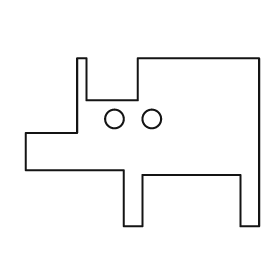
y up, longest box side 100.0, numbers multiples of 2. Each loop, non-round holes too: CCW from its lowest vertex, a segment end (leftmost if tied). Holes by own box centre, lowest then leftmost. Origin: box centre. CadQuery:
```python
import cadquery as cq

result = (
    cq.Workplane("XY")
    .moveTo(-8.0, -36.0)
    .lineTo(0.0, -36.0)
    .lineTo(0.0, -14.0)
    .lineTo(42.0, -14.0)
    .lineTo(42.0, -36.0)
    .lineTo(50.0, -36.0)
    .lineTo(50.0, 36.0)
    .lineTo(-2.0, 36.0)
    .lineTo(-2.0, 18.0)
    .lineTo(-24.0, 18.0)
    .lineTo(-24.0, 36.0)
    .lineTo(-28.0, 36.0)
    .lineTo(-28.0, 4.0)
    .lineTo(-50.0, 4.0)
    .lineTo(-50.0, -12.0)
    .lineTo(-8.0, -12.0)
    .close()
    .moveTo(-12.0, 10.0)
    .circle(4.0)
    .moveTo(4.0, 10.0)
    .circle(4.0)
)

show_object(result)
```